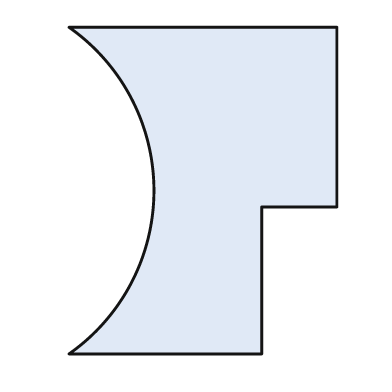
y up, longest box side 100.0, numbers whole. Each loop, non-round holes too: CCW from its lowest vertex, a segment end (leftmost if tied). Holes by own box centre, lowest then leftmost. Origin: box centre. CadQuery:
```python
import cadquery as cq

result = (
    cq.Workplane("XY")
    .moveTo(-41.0, -50.0)
    .lineTo(18.0, -50.0)
    .lineTo(18.0, -5.0)
    .lineTo(41.0, -5.0)
    .lineTo(41.0, 50.0)
    .lineTo(-41.0, 50.0)
    .threePointArc((-15.0, 0.0), (-41.0, -50.0))
    .close()
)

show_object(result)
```